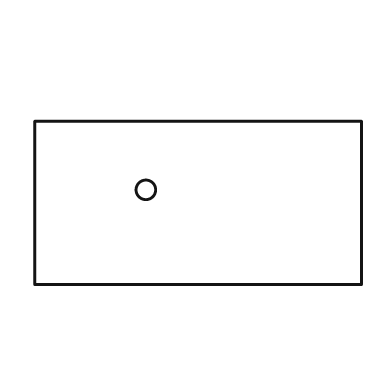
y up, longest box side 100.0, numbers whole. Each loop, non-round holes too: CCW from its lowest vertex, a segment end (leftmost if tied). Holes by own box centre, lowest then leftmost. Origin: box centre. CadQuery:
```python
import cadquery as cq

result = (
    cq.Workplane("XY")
    .moveTo(-50.0, -25.0)
    .lineTo(50.0, -25.0)
    .lineTo(50.0, 25.0)
    .lineTo(-50.0, 25.0)
    .close()
    .moveTo(-16.0, 4.0)
    .circle(3.0)
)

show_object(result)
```